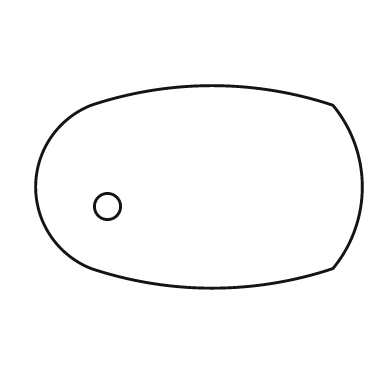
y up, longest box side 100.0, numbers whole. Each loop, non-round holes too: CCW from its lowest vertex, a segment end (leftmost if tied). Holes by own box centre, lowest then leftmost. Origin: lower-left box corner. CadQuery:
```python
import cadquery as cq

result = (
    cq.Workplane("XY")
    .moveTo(17.0, 6.0)
    .threePointArc((54.0, 0.0), (91.0, 6.0))
    .threePointArc((100.0, 31.0), (91.0, 56.0))
    .threePointArc((54.0, 62.0), (17.0, 56.0))
    .threePointArc((0.0, 31.0), (17.0, 6.0))
    .close()
    .moveTo(22.0, 25.0)
    .circle(4.0)
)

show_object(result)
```